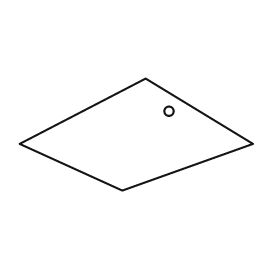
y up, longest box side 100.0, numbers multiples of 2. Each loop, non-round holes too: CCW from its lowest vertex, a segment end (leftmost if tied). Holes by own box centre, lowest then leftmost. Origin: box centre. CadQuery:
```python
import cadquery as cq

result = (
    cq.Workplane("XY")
    .moveTo(-6.0, -24.0)
    .lineTo(50.0, -4.0)
    .lineTo(4.0, 24.0)
    .lineTo(-50.0, -4.0)
    .close()
    .moveTo(14.0, 10.0)
    .circle(2.0)
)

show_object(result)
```